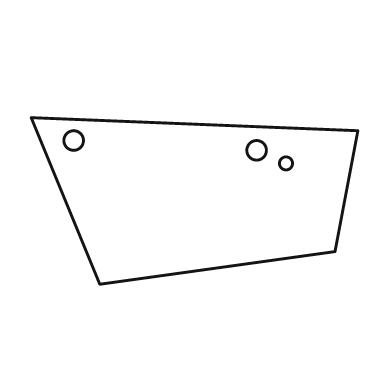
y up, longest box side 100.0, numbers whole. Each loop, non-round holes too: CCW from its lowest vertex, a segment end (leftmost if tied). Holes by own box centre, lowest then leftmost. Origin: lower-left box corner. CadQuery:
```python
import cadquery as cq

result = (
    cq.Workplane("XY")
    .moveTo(21.0, 0.0)
    .lineTo(93.0, 10.0)
    .lineTo(100.0, 47.0)
    .lineTo(0.0, 51.0)
    .close()
    .moveTo(78.0, 37.0)
    .circle(2.0)
    .moveTo(69.0, 41.0)
    .circle(3.0)
    .moveTo(13.0, 44.0)
    .circle(3.0)
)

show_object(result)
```